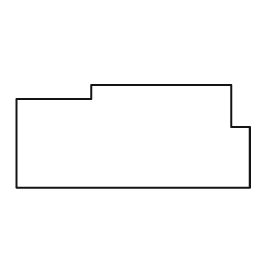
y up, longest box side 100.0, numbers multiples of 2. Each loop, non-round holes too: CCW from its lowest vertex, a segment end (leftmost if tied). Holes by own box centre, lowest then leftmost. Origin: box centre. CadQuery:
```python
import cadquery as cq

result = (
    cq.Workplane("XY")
    .moveTo(-50.0, -22.0)
    .lineTo(50.0, -22.0)
    .lineTo(50.0, 4.0)
    .lineTo(42.0, 4.0)
    .lineTo(42.0, 22.0)
    .lineTo(-18.0, 22.0)
    .lineTo(-18.0, 16.0)
    .lineTo(-50.0, 16.0)
    .close()
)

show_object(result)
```